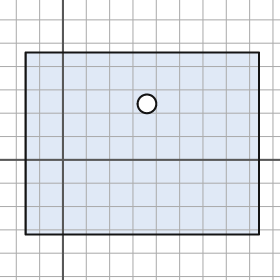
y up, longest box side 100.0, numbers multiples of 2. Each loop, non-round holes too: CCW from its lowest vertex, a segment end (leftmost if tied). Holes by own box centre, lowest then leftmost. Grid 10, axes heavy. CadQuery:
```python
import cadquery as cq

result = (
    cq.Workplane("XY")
    .moveTo(-16.0, -32.0)
    .lineTo(84.0, -32.0)
    .lineTo(84.0, 46.0)
    .lineTo(-16.0, 46.0)
    .close()
    .moveTo(36.0, 24.0)
    .circle(4.0)
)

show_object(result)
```